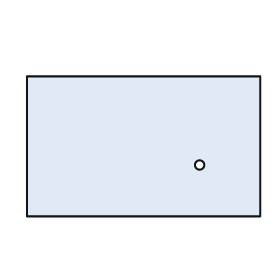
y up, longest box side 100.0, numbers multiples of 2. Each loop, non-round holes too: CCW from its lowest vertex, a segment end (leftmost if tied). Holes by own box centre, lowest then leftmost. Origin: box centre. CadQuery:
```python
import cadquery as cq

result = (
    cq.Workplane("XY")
    .moveTo(-50.0, -30.0)
    .lineTo(50.0, -30.0)
    .lineTo(50.0, 30.0)
    .lineTo(-50.0, 30.0)
    .close()
    .moveTo(24.0, -8.0)
    .circle(2.0)
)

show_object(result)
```